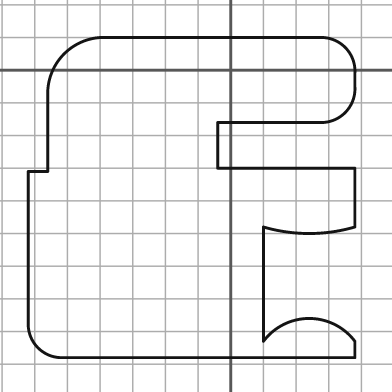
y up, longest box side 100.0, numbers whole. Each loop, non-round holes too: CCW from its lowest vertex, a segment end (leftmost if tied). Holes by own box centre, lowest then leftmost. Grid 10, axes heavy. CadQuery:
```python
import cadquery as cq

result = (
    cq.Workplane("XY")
    .moveTo(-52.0, -88.0)
    .lineTo(38.0, -88.0)
    .lineTo(38.0, -83.0)
    .threePointArc((24.0, -76.0), (10.0, -83.0))
    .lineTo(10.0, -48.0)
    .threePointArc((24.0, -50.0), (38.0, -48.0))
    .lineTo(38.0, -30.0)
    .lineTo(-4.0, -30.0)
    .lineTo(-4.0, -16.0)
    .lineTo(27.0, -16.0)
    .threePointArc((35.0, -13.0), (38.0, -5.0))
    .lineTo(38.0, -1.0)
    .threePointArc((35.0, 7.0), (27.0, 10.0))
    .lineTo(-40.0, 10.0)
    .threePointArc((-51.0, 5.0), (-56.0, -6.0))
    .lineTo(-56.0, -31.0)
    .lineTo(-62.0, -31.0)
    .lineTo(-62.0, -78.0)
    .threePointArc((-59.0, -85.0), (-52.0, -88.0))
    .close()
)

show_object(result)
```